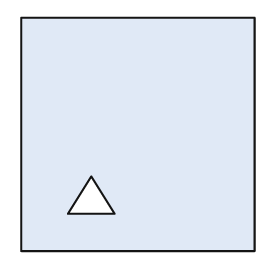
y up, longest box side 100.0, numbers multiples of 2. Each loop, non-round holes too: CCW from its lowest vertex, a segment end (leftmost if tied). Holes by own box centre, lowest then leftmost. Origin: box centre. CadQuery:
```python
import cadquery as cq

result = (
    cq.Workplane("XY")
    .moveTo(-50.0, -50.0)
    .lineTo(50.0, -50.0)
    .lineTo(50.0, 50.0)
    .lineTo(-50.0, 50.0)
    .close()
    .moveTo(-30.0, -34.0)
    .lineTo(-10.0, -34.0)
    .lineTo(-20.0, -18.0)
    .close()
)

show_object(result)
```